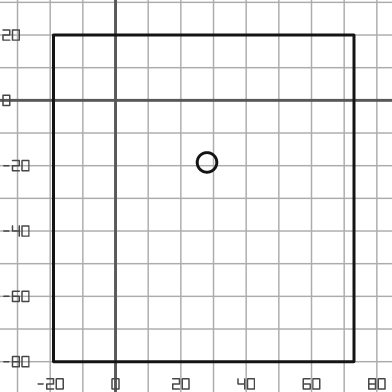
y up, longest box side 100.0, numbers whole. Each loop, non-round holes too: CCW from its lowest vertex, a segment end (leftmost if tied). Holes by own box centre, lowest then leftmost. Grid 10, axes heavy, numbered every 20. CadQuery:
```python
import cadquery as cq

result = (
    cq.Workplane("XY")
    .moveTo(-19.0, -80.0)
    .lineTo(73.0, -80.0)
    .lineTo(73.0, 20.0)
    .lineTo(-19.0, 20.0)
    .close()
    .moveTo(28.0, -19.0)
    .circle(3.0)
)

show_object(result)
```